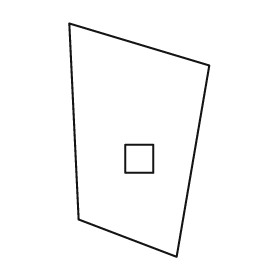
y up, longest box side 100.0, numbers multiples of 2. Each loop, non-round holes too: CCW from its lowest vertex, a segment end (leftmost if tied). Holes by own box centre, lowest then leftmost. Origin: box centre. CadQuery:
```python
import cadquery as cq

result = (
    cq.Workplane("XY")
    .moveTo(16.0, -50.0)
    .lineTo(30.0, 32.0)
    .lineTo(-30.0, 50.0)
    .lineTo(-26.0, -34.0)
    .close()
    .moveTo(-6.0, -14.0)
    .lineTo(6.0, -14.0)
    .lineTo(6.0, -2.0)
    .lineTo(-6.0, -2.0)
    .close()
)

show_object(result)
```